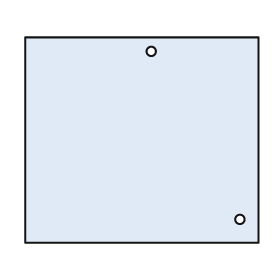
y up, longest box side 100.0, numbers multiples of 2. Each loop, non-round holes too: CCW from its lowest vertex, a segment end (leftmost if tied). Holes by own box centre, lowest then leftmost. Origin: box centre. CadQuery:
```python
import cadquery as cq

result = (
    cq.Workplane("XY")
    .moveTo(-50.0, -44.0)
    .lineTo(50.0, -44.0)
    .lineTo(50.0, 44.0)
    .lineTo(-50.0, 44.0)
    .close()
    .moveTo(42.0, -34.0)
    .circle(2.0)
    .moveTo(4.0, 38.0)
    .circle(2.0)
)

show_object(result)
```